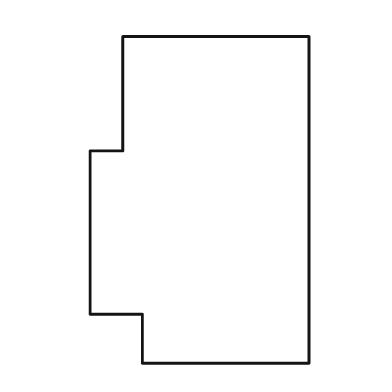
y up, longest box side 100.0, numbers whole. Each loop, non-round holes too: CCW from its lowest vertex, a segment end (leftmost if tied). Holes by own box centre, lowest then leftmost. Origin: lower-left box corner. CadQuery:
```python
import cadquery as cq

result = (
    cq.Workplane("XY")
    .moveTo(16.0, 0.0)
    .lineTo(67.0, 0.0)
    .lineTo(67.0, 100.0)
    .lineTo(10.0, 100.0)
    .lineTo(10.0, 65.0)
    .lineTo(0.0, 65.0)
    .lineTo(0.0, 15.0)
    .lineTo(16.0, 15.0)
    .close()
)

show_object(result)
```